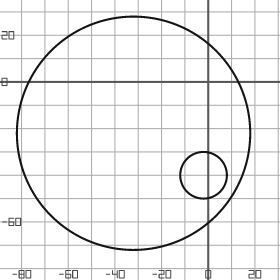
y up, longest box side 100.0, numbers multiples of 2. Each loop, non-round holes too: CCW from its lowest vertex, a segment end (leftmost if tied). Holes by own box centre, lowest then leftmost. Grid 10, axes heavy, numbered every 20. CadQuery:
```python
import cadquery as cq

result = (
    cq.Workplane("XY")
    .moveTo(-32.0, -22.0)
    .circle(50.0)
    .moveTo(-2.0, -40.0)
    .circle(10.0)
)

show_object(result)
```